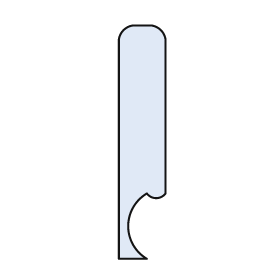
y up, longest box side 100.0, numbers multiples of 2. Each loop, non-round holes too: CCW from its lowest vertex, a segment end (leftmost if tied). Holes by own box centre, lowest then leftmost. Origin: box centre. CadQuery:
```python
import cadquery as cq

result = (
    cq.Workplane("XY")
    .moveTo(-10.0, -50.0)
    .lineTo(2.0, -50.0)
    .threePointArc((-6.0, -36.0), (2.0, -22.0))
    .threePointArc((6.0, -24.0), (10.0, -22.0))
    .lineTo(10.0, 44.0)
    .threePointArc((8.0, 48.0), (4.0, 50.0))
    .lineTo(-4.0, 50.0)
    .threePointArc((-8.0, 48.0), (-10.0, 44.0))
    .close()
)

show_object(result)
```